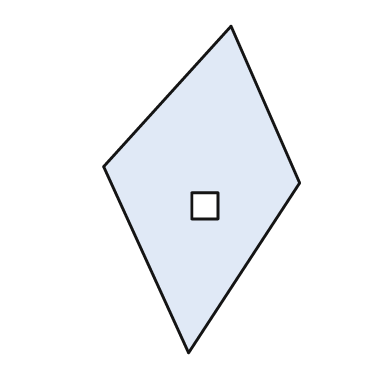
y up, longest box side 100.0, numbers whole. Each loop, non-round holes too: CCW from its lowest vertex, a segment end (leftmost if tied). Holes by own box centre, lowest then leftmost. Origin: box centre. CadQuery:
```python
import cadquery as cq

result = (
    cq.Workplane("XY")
    .moveTo(-4.0, -50.0)
    .lineTo(30.0, 2.0)
    .lineTo(9.0, 50.0)
    .lineTo(-30.0, 7.0)
    .close()
    .moveTo(-3.0, -9.0)
    .lineTo(5.0, -9.0)
    .lineTo(5.0, -1.0)
    .lineTo(-3.0, -1.0)
    .close()
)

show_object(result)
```